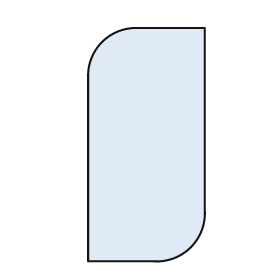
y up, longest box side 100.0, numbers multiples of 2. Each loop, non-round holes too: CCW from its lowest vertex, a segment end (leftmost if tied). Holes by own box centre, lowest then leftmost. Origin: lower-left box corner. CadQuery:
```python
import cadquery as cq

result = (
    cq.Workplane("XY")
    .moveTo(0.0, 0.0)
    .lineTo(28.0, 0.0)
    .threePointArc((44.0, 6.0), (50.0, 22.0))
    .lineTo(50.0, 100.0)
    .lineTo(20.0, 100.0)
    .threePointArc((6.0, 94.0), (0.0, 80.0))
    .close()
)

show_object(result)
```